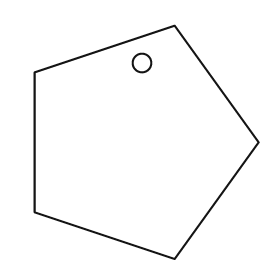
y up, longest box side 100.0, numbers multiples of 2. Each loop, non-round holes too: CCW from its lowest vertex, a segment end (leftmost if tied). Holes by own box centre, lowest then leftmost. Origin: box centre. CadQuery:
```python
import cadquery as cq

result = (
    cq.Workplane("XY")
    .moveTo(12.0, -50.0)
    .lineTo(48.0, 0.0)
    .lineTo(12.0, 50.0)
    .lineTo(-48.0, 30.0)
    .lineTo(-48.0, -30.0)
    .close()
    .moveTo(-2.0, 34.0)
    .circle(4.0)
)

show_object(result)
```